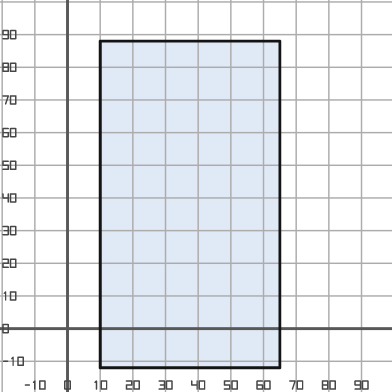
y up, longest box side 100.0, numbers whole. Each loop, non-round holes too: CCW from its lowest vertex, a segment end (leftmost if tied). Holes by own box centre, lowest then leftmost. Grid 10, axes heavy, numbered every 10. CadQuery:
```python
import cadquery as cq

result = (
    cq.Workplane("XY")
    .moveTo(10.0, -12.0)
    .lineTo(65.0, -12.0)
    .lineTo(65.0, 88.0)
    .lineTo(10.0, 88.0)
    .close()
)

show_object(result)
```